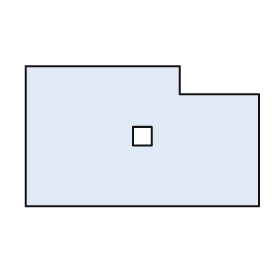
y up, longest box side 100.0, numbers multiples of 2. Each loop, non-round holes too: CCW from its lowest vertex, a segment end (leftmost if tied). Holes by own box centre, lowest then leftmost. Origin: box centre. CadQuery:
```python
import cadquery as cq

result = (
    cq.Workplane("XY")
    .moveTo(-50.0, -30.0)
    .lineTo(50.0, -30.0)
    .lineTo(50.0, 18.0)
    .lineTo(16.0, 18.0)
    .lineTo(16.0, 30.0)
    .lineTo(-50.0, 30.0)
    .close()
    .moveTo(-4.0, -4.0)
    .lineTo(4.0, -4.0)
    .lineTo(4.0, 4.0)
    .lineTo(-4.0, 4.0)
    .close()
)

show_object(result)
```